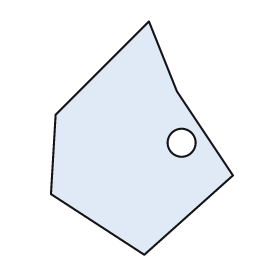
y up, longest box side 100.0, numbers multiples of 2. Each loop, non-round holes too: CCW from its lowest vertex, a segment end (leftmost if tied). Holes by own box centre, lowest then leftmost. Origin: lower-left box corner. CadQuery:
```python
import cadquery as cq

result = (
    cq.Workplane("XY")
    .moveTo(40.0, 0.0)
    .lineTo(78.0, 34.0)
    .lineTo(54.0, 70.0)
    .lineTo(42.0, 100.0)
    .lineTo(2.0, 60.0)
    .lineTo(0.0, 26.0)
    .close()
    .moveTo(56.0, 48.0)
    .circle(6.0)
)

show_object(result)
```